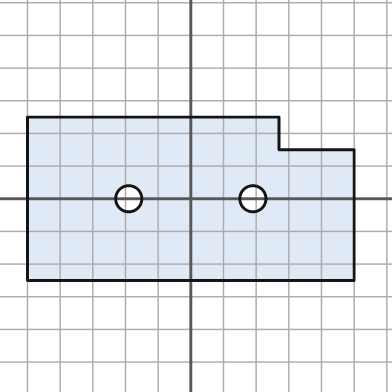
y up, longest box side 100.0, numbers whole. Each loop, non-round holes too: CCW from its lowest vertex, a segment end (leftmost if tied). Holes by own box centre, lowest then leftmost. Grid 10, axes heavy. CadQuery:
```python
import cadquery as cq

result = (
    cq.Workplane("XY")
    .moveTo(-50.0, -25.0)
    .lineTo(50.0, -25.0)
    .lineTo(50.0, 15.0)
    .lineTo(27.0, 15.0)
    .lineTo(27.0, 25.0)
    .lineTo(-50.0, 25.0)
    .close()
    .moveTo(-19.0, 0.0)
    .circle(4.0)
    .moveTo(19.0, 0.0)
    .circle(4.0)
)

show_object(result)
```